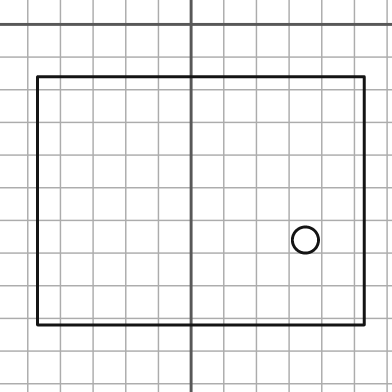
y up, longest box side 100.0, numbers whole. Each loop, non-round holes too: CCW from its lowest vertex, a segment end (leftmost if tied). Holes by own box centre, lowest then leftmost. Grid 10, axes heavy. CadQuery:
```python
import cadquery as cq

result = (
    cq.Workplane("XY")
    .moveTo(-47.0, -92.0)
    .lineTo(53.0, -92.0)
    .lineTo(53.0, -16.0)
    .lineTo(-47.0, -16.0)
    .close()
    .moveTo(35.0, -66.0)
    .circle(4.0)
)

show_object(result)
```